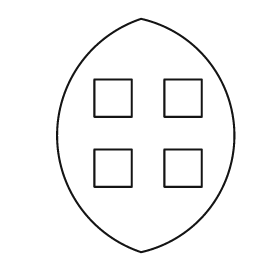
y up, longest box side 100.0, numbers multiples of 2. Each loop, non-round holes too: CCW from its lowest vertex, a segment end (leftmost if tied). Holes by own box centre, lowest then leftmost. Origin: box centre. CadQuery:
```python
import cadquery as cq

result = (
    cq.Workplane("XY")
    .moveTo(-2.0, -50.0)
    .threePointArc((38.0, 0.0), (-2.0, 50.0))
    .threePointArc((-38.0, 0.0), (-2.0, -50.0))
    .close()
    .moveTo(-22.0, -22.0)
    .lineTo(-6.0, -22.0)
    .lineTo(-6.0, -6.0)
    .lineTo(-22.0, -6.0)
    .close()
    .moveTo(8.0, -22.0)
    .lineTo(24.0, -22.0)
    .lineTo(24.0, -6.0)
    .lineTo(8.0, -6.0)
    .close()
    .moveTo(-22.0, 8.0)
    .lineTo(-6.0, 8.0)
    .lineTo(-6.0, 24.0)
    .lineTo(-22.0, 24.0)
    .close()
    .moveTo(8.0, 8.0)
    .lineTo(24.0, 8.0)
    .lineTo(24.0, 24.0)
    .lineTo(8.0, 24.0)
    .close()
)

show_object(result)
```